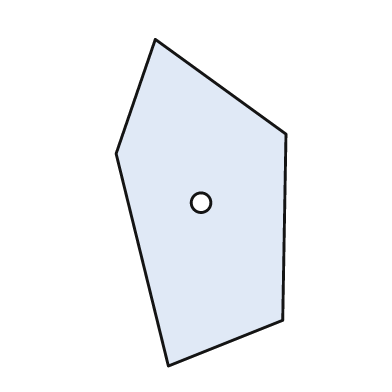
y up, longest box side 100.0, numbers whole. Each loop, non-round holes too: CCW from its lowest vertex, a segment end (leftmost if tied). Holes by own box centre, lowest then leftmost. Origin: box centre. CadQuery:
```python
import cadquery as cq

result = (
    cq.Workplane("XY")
    .moveTo(-10.0, -50.0)
    .lineTo(25.0, -36.0)
    .lineTo(26.0, 21.0)
    .lineTo(-14.0, 50.0)
    .lineTo(-26.0, 15.0)
    .close()
    .moveTo(0.0, 0.0)
    .circle(3.0)
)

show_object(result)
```